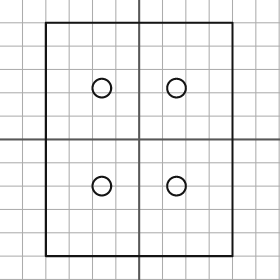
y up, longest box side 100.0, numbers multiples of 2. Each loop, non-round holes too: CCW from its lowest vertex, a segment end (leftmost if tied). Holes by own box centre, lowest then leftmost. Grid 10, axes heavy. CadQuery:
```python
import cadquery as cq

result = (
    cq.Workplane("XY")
    .moveTo(-40.0, -50.0)
    .lineTo(40.0, -50.0)
    .lineTo(40.0, 50.0)
    .lineTo(-40.0, 50.0)
    .close()
    .moveTo(-16.0, -20.0)
    .circle(4.0)
    .moveTo(16.0, -20.0)
    .circle(4.0)
    .moveTo(-16.0, 22.0)
    .circle(4.0)
    .moveTo(16.0, 22.0)
    .circle(4.0)
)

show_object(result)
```